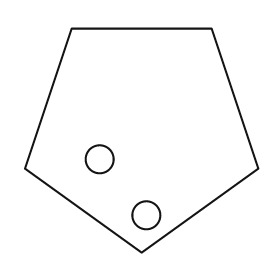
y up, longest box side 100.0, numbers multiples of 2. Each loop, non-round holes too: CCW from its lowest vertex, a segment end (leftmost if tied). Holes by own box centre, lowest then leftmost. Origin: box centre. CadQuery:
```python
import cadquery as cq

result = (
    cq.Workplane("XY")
    .moveTo(0.0, -48.0)
    .lineTo(50.0, -12.0)
    .lineTo(30.0, 48.0)
    .lineTo(-30.0, 48.0)
    .lineTo(-50.0, -12.0)
    .close()
    .moveTo(2.0, -32.0)
    .circle(6.0)
    .moveTo(-18.0, -8.0)
    .circle(6.0)
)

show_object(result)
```